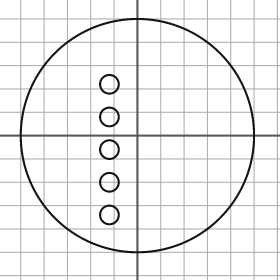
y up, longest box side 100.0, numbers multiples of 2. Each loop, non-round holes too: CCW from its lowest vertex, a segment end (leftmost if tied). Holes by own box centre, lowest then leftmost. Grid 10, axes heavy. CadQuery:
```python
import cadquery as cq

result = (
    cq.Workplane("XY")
    .moveTo(0.0, 0.0)
    .circle(50.0)
    .moveTo(-12.0, -34.0)
    .circle(4.0)
    .moveTo(-12.0, -20.0)
    .circle(4.0)
    .moveTo(-12.0, -6.0)
    .circle(4.0)
    .moveTo(-12.0, 8.0)
    .circle(4.0)
    .moveTo(-12.0, 22.0)
    .circle(4.0)
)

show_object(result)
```